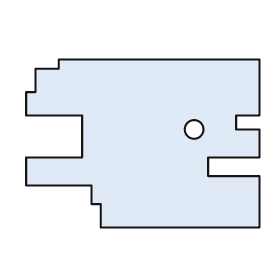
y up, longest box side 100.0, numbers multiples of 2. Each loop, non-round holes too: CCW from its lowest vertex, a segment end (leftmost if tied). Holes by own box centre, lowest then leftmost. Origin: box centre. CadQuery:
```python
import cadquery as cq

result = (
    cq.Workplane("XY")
    .moveTo(-18.0, -36.0)
    .lineTo(50.0, -36.0)
    .lineTo(50.0, -14.0)
    .lineTo(28.0, -14.0)
    .lineTo(28.0, -6.0)
    .lineTo(50.0, -6.0)
    .lineTo(50.0, 6.0)
    .lineTo(40.0, 6.0)
    .lineTo(40.0, 12.0)
    .lineTo(50.0, 12.0)
    .lineTo(50.0, 36.0)
    .lineTo(-36.0, 36.0)
    .lineTo(-36.0, 32.0)
    .lineTo(-46.0, 32.0)
    .lineTo(-46.0, 22.0)
    .lineTo(-50.0, 22.0)
    .lineTo(-50.0, 12.0)
    .lineTo(-26.0, 12.0)
    .lineTo(-26.0, -6.0)
    .lineTo(-50.0, -6.0)
    .lineTo(-50.0, -18.0)
    .lineTo(-22.0, -18.0)
    .lineTo(-22.0, -26.0)
    .lineTo(-18.0, -26.0)
    .close()
    .moveTo(22.0, 6.0)
    .circle(4.0)
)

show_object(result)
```